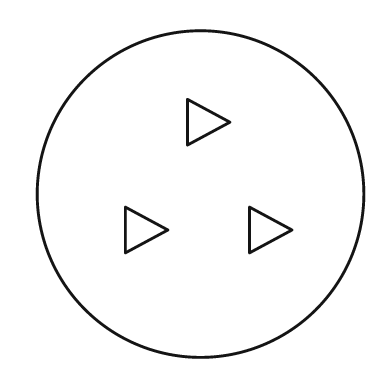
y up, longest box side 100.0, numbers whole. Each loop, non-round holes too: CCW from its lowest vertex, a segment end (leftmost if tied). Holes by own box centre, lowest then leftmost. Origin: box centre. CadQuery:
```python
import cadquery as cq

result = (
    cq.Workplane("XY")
    .moveTo(0.0, 0.0)
    .circle(50.0)
    .moveTo(-23.0, -18.0)
    .lineTo(-10.0, -11.0)
    .lineTo(-23.0, -4.0)
    .close()
    .moveTo(15.0, -18.0)
    .lineTo(28.0, -11.0)
    .lineTo(15.0, -4.0)
    .close()
    .moveTo(-4.0, 15.0)
    .lineTo(9.0, 22.0)
    .lineTo(-4.0, 29.0)
    .close()
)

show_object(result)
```